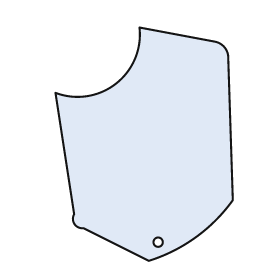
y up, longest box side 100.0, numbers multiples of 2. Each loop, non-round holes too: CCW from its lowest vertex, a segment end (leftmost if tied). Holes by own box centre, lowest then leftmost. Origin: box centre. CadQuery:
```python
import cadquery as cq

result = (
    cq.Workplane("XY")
    .moveTo(2.0, -50.0)
    .threePointArc((22.0, -40.0), (38.0, -24.0))
    .lineTo(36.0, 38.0)
    .threePointArc((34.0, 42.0), (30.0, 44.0))
    .lineTo(-2.0, 50.0)
    .threePointArc((-12.0, 26.0), (-38.0, 22.0))
    .lineTo(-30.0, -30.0)
    .threePointArc((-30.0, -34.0), (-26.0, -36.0))
    .close()
    .moveTo(6.0, -42.0)
    .circle(2.0)
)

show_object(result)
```